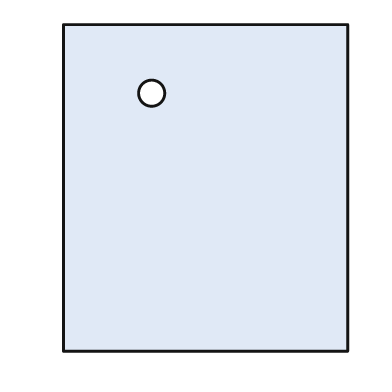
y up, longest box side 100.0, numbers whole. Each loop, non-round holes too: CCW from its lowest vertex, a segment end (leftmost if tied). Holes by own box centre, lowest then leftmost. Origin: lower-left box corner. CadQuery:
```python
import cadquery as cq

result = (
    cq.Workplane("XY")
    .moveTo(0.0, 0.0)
    .lineTo(87.0, 0.0)
    .lineTo(87.0, 100.0)
    .lineTo(0.0, 100.0)
    .close()
    .moveTo(27.0, 79.0)
    .circle(4.0)
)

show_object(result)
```